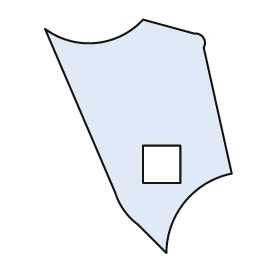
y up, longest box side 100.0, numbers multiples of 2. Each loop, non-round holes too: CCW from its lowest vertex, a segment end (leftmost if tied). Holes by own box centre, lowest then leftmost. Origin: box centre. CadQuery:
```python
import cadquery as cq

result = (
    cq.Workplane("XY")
    .moveTo(12.0, -50.0)
    .threePointArc((20.0, -28.0), (40.0, -16.0))
    .lineTo(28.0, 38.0)
    .threePointArc((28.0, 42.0), (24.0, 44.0))
    .lineTo(2.0, 50.0)
    .threePointArc((-18.0, 40.0), (-40.0, 46.0))
    .lineTo(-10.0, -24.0)
    .threePointArc((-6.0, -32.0), (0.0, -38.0))
    .close()
    .moveTo(2.0, -20.0)
    .lineTo(18.0, -20.0)
    .lineTo(18.0, -4.0)
    .lineTo(2.0, -4.0)
    .close()
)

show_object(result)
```